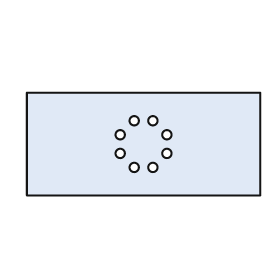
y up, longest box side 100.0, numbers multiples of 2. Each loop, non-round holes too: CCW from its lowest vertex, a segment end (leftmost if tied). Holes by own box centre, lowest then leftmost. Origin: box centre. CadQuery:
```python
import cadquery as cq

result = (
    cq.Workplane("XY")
    .moveTo(-50.0, -22.0)
    .lineTo(50.0, -22.0)
    .lineTo(50.0, 22.0)
    .lineTo(-50.0, 22.0)
    .close()
    .moveTo(-4.0, -10.0)
    .circle(2.0)
    .moveTo(4.0, -10.0)
    .circle(2.0)
    .moveTo(-10.0, -4.0)
    .circle(2.0)
    .moveTo(10.0, -4.0)
    .circle(2.0)
    .moveTo(-10.0, 4.0)
    .circle(2.0)
    .moveTo(10.0, 4.0)
    .circle(2.0)
    .moveTo(-4.0, 10.0)
    .circle(2.0)
    .moveTo(4.0, 10.0)
    .circle(2.0)
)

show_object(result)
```